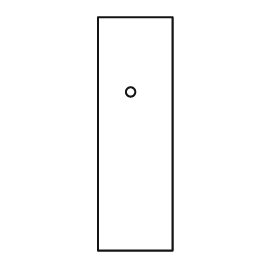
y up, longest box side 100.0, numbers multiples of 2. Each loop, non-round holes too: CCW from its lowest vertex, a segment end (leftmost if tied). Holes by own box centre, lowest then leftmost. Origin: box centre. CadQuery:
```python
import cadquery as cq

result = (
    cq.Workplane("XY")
    .moveTo(-16.0, -50.0)
    .lineTo(16.0, -50.0)
    .lineTo(16.0, 50.0)
    .lineTo(-16.0, 50.0)
    .close()
    .moveTo(-2.0, 18.0)
    .circle(2.0)
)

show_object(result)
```